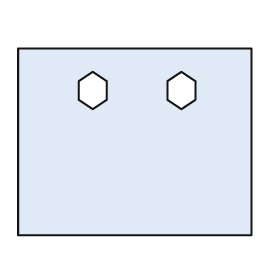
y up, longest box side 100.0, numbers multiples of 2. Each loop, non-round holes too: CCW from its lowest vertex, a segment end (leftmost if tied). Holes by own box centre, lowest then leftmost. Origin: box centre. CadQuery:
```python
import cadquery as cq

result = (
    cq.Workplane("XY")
    .moveTo(-50.0, -40.0)
    .lineTo(50.0, -40.0)
    .lineTo(50.0, 40.0)
    .lineTo(-50.0, 40.0)
    .close()
    .moveTo(-18.0, 14.0)
    .lineTo(-12.0, 18.0)
    .lineTo(-12.0, 26.0)
    .lineTo(-18.0, 30.0)
    .lineTo(-24.0, 26.0)
    .lineTo(-24.0, 18.0)
    .close()
    .moveTo(20.0, 14.0)
    .lineTo(26.0, 18.0)
    .lineTo(26.0, 26.0)
    .lineTo(20.0, 30.0)
    .lineTo(14.0, 26.0)
    .lineTo(14.0, 18.0)
    .close()
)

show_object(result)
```